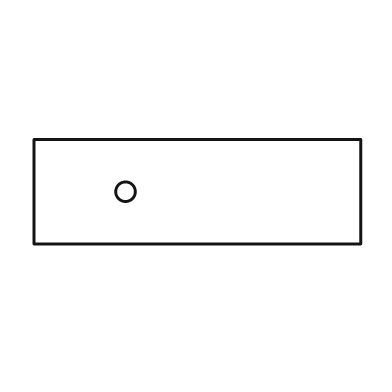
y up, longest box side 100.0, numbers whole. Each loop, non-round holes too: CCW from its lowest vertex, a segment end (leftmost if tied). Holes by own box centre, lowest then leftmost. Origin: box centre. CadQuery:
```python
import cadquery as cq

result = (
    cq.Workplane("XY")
    .moveTo(-50.0, -16.0)
    .lineTo(50.0, -16.0)
    .lineTo(50.0, 16.0)
    .lineTo(-50.0, 16.0)
    .close()
    .moveTo(-22.0, 0.0)
    .circle(3.0)
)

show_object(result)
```